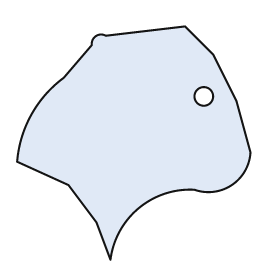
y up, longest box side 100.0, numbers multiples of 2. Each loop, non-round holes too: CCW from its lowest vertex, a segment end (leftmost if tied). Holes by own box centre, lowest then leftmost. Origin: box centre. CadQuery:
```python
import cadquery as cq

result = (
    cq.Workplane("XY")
    .moveTo(-10.0, -50.0)
    .threePointArc((2.0, -28.0), (26.0, -20.0))
    .threePointArc((42.0, -18.0), (50.0, -4.0))
    .lineTo(44.0, 18.0)
    .lineTo(34.0, 38.0)
    .lineTo(22.0, 50.0)
    .lineTo(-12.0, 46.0)
    .threePointArc((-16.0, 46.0), (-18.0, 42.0))
    .lineTo(-30.0, 28.0)
    .threePointArc((-44.0, 12.0), (-50.0, -8.0))
    .lineTo(-28.0, -18.0)
    .lineTo(-16.0, -34.0)
    .close()
    .moveTo(30.0, 20.0)
    .circle(4.0)
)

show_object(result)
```